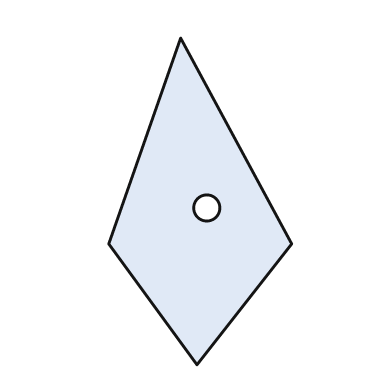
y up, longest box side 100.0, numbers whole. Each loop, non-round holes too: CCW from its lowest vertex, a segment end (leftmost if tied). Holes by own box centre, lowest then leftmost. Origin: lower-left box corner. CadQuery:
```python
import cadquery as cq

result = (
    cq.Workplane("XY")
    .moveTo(27.0, 0.0)
    .lineTo(56.0, 37.0)
    .lineTo(22.0, 100.0)
    .lineTo(0.0, 37.0)
    .close()
    .moveTo(30.0, 48.0)
    .circle(4.0)
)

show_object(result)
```